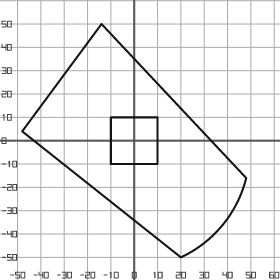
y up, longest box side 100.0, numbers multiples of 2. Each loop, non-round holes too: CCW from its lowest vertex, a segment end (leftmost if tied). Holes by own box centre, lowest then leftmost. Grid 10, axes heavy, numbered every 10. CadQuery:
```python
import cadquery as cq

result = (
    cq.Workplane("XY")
    .moveTo(20.0, -50.0)
    .threePointArc((38.0, -36.0), (48.0, -16.0))
    .lineTo(-14.0, 50.0)
    .lineTo(-48.0, 4.0)
    .close()
    .moveTo(-10.0, -10.0)
    .lineTo(10.0, -10.0)
    .lineTo(10.0, 10.0)
    .lineTo(-10.0, 10.0)
    .close()
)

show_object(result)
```